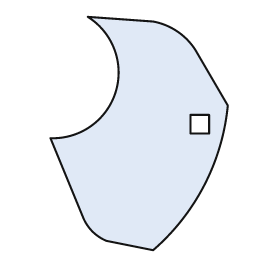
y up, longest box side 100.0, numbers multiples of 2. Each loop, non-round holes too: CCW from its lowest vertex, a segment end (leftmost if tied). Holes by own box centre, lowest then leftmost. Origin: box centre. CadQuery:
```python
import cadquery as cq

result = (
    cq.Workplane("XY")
    .moveTo(6.0, -50.0)
    .threePointArc((28.0, -22.0), (38.0, 12.0))
    .lineTo(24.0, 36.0)
    .threePointArc((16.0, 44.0), (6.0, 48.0))
    .lineTo(-22.0, 50.0)
    .threePointArc((-10.0, 18.0), (-38.0, -2.0))
    .lineTo(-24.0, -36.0)
    .threePointArc((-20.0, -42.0), (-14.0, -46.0))
    .close()
    .moveTo(22.0, 0.0)
    .lineTo(30.0, 0.0)
    .lineTo(30.0, 8.0)
    .lineTo(22.0, 8.0)
    .close()
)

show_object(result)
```